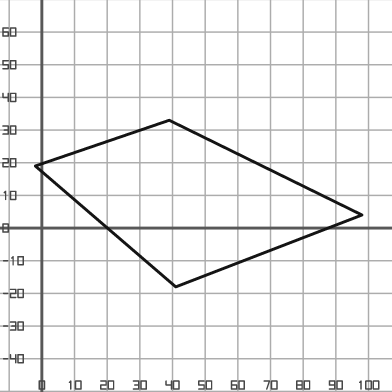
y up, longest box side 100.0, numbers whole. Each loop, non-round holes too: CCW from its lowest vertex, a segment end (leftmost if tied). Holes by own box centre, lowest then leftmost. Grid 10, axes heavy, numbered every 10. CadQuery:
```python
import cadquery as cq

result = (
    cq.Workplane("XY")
    .moveTo(41.0, -18.0)
    .lineTo(98.0, 4.0)
    .lineTo(39.0, 33.0)
    .lineTo(-2.0, 19.0)
    .close()
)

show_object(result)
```